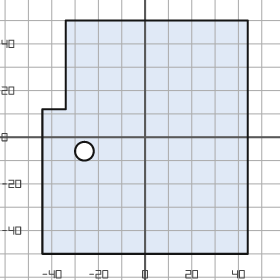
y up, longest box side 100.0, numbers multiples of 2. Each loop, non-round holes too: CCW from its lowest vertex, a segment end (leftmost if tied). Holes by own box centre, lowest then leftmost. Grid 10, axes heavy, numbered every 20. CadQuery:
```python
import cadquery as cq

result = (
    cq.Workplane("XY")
    .moveTo(-44.0, -50.0)
    .lineTo(44.0, -50.0)
    .lineTo(44.0, 50.0)
    .lineTo(-34.0, 50.0)
    .lineTo(-34.0, 12.0)
    .lineTo(-44.0, 12.0)
    .close()
    .moveTo(-26.0, -6.0)
    .circle(4.0)
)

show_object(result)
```